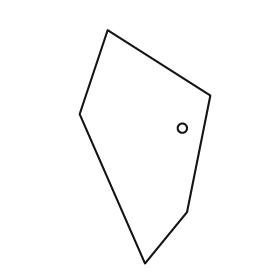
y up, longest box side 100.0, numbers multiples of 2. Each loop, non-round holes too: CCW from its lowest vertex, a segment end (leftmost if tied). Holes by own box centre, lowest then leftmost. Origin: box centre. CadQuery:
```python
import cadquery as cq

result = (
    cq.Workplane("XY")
    .moveTo(0.0, -50.0)
    .lineTo(18.0, -28.0)
    .lineTo(28.0, 22.0)
    .lineTo(-16.0, 50.0)
    .lineTo(-28.0, 14.0)
    .close()
    .moveTo(16.0, 8.0)
    .circle(2.0)
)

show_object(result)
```